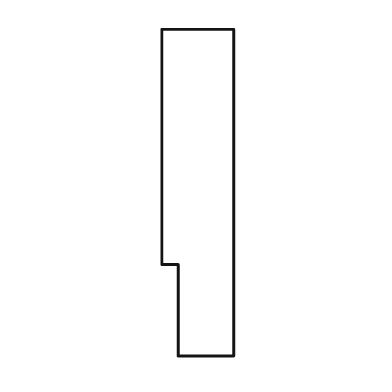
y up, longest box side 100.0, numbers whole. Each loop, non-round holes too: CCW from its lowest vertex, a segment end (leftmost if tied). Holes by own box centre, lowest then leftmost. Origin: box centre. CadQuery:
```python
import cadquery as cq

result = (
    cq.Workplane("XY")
    .moveTo(-6.0, -50.0)
    .lineTo(11.0, -50.0)
    .lineTo(11.0, 50.0)
    .lineTo(-11.0, 50.0)
    .lineTo(-11.0, -22.0)
    .lineTo(-6.0, -22.0)
    .close()
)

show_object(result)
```